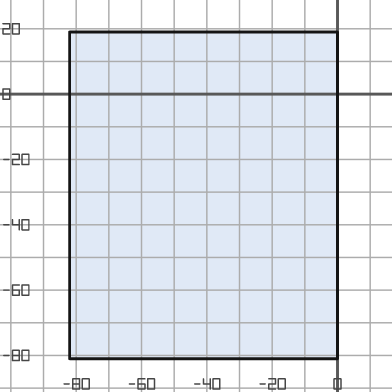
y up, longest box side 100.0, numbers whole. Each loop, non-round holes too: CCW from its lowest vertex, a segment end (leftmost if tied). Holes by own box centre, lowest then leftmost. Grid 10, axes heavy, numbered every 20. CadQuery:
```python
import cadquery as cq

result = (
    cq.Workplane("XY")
    .moveTo(-82.0, -81.0)
    .lineTo(0.0, -81.0)
    .lineTo(0.0, 19.0)
    .lineTo(-82.0, 19.0)
    .close()
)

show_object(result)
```